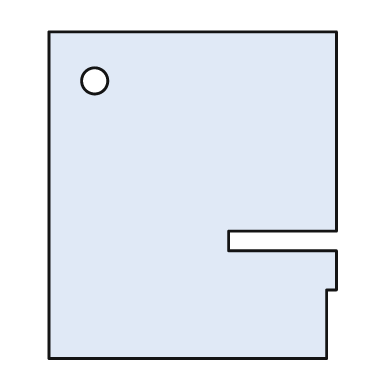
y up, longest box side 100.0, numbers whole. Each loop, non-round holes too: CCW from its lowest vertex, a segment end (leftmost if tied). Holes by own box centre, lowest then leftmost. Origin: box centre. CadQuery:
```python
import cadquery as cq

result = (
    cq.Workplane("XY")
    .moveTo(-44.0, -50.0)
    .lineTo(41.0, -50.0)
    .lineTo(41.0, -29.0)
    .lineTo(44.0, -29.0)
    .lineTo(44.0, -17.0)
    .lineTo(11.0, -17.0)
    .lineTo(11.0, -11.0)
    .lineTo(44.0, -11.0)
    .lineTo(44.0, 50.0)
    .lineTo(-44.0, 50.0)
    .close()
    .moveTo(-30.0, 35.0)
    .circle(4.0)
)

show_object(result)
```